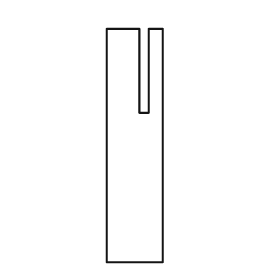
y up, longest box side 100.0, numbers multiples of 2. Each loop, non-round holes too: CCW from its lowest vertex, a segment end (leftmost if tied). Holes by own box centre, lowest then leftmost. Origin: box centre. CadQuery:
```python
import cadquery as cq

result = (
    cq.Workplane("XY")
    .moveTo(-12.0, -50.0)
    .lineTo(12.0, -50.0)
    .lineTo(12.0, 50.0)
    .lineTo(6.0, 50.0)
    .lineTo(6.0, 14.0)
    .lineTo(2.0, 14.0)
    .lineTo(2.0, 50.0)
    .lineTo(-12.0, 50.0)
    .close()
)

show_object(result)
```